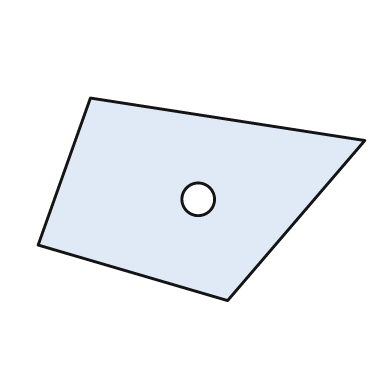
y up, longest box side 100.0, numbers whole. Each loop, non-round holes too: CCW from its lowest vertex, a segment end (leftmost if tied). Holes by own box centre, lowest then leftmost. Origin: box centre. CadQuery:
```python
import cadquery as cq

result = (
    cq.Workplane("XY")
    .moveTo(8.0, -31.0)
    .lineTo(50.0, 18.0)
    .lineTo(-34.0, 31.0)
    .lineTo(-50.0, -14.0)
    .close()
    .moveTo(-1.0, 0.0)
    .circle(5.0)
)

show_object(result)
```